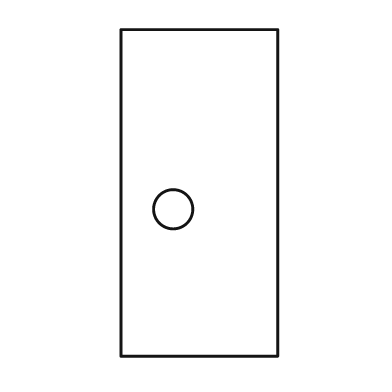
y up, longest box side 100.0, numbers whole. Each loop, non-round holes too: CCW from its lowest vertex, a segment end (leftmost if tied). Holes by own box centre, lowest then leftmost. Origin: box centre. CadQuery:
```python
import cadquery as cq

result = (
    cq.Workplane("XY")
    .moveTo(-24.0, -50.0)
    .lineTo(24.0, -50.0)
    .lineTo(24.0, 50.0)
    .lineTo(-24.0, 50.0)
    .close()
    .moveTo(-8.0, -5.0)
    .circle(6.0)
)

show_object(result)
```